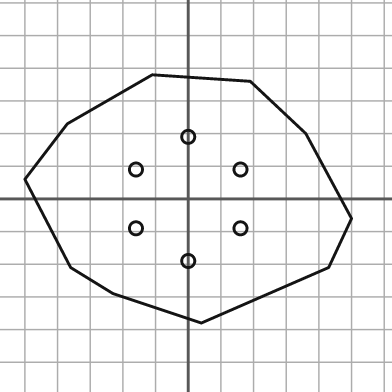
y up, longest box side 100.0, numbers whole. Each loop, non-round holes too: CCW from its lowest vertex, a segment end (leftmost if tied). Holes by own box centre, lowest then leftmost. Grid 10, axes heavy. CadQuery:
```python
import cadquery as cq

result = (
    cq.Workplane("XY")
    .moveTo(4.0, -38.0)
    .lineTo(43.0, -21.0)
    .lineTo(50.0, -6.0)
    .lineTo(36.0, 20.0)
    .lineTo(19.0, 36.0)
    .lineTo(-11.0, 38.0)
    .lineTo(-37.0, 23.0)
    .lineTo(-50.0, 6.0)
    .lineTo(-36.0, -21.0)
    .lineTo(-23.0, -29.0)
    .close()
    .moveTo(0.0, -19.0)
    .circle(2.0)
    .moveTo(-16.0, -9.0)
    .circle(2.0)
    .moveTo(16.0, -9.0)
    .circle(2.0)
    .moveTo(-16.0, 9.0)
    .circle(2.0)
    .moveTo(16.0, 9.0)
    .circle(2.0)
    .moveTo(0.0, 19.0)
    .circle(2.0)
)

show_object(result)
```